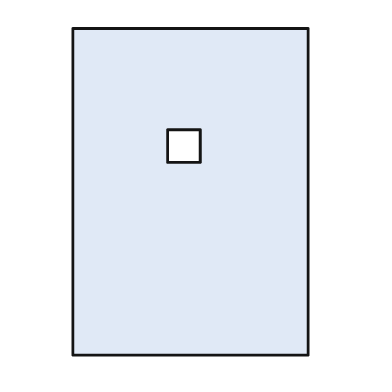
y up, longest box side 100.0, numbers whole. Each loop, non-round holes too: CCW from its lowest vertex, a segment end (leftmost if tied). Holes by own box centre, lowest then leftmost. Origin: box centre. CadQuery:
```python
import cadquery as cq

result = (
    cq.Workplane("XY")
    .moveTo(-36.0, -50.0)
    .lineTo(36.0, -50.0)
    .lineTo(36.0, 50.0)
    .lineTo(-36.0, 50.0)
    .close()
    .moveTo(-7.0, 9.0)
    .lineTo(3.0, 9.0)
    .lineTo(3.0, 19.0)
    .lineTo(-7.0, 19.0)
    .close()
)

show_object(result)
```